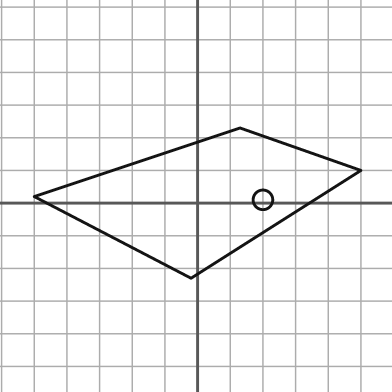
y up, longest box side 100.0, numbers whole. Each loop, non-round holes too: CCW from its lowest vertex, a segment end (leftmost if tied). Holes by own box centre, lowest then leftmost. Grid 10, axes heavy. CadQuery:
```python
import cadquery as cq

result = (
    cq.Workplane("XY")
    .moveTo(-2.0, -23.0)
    .lineTo(50.0, 10.0)
    .lineTo(13.0, 23.0)
    .lineTo(-50.0, 2.0)
    .close()
    .moveTo(20.0, 1.0)
    .circle(3.0)
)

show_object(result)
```